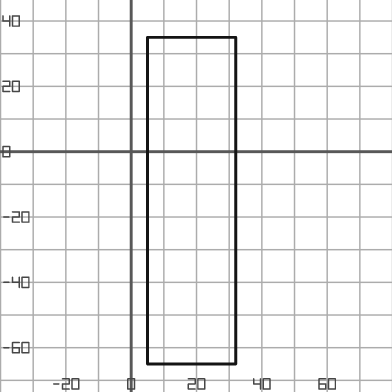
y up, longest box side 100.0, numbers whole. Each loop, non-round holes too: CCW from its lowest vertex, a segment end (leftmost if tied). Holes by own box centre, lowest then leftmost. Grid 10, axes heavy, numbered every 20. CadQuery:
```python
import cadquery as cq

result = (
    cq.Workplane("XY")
    .moveTo(5.0, -65.0)
    .lineTo(32.0, -65.0)
    .lineTo(32.0, 35.0)
    .lineTo(5.0, 35.0)
    .close()
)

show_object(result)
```